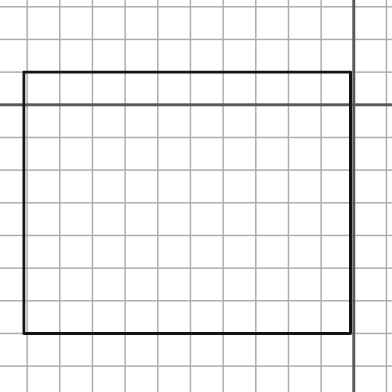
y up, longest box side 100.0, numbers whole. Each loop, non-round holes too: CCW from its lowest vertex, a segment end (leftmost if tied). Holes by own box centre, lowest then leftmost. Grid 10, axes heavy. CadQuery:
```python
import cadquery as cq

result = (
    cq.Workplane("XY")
    .moveTo(-101.0, -70.0)
    .lineTo(-1.0, -70.0)
    .lineTo(-1.0, 10.0)
    .lineTo(-101.0, 10.0)
    .close()
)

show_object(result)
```